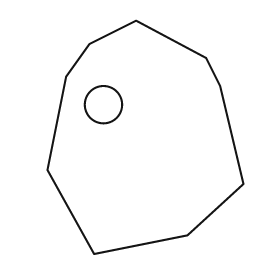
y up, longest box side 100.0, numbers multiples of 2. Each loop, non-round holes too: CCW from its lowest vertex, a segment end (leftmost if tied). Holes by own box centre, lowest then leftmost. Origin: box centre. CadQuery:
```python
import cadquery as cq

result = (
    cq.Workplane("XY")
    .moveTo(-22.0, -50.0)
    .lineTo(18.0, -42.0)
    .lineTo(42.0, -20.0)
    .lineTo(32.0, 22.0)
    .lineTo(26.0, 34.0)
    .lineTo(-4.0, 50.0)
    .lineTo(-24.0, 40.0)
    .lineTo(-34.0, 26.0)
    .lineTo(-42.0, -14.0)
    .close()
    .moveTo(-18.0, 14.0)
    .circle(8.0)
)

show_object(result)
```